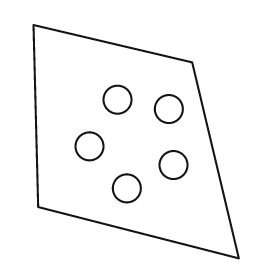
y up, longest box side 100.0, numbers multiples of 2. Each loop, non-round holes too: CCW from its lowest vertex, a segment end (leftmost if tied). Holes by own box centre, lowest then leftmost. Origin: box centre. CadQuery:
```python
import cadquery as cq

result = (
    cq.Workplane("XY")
    .moveTo(44.0, -50.0)
    .lineTo(24.0, 34.0)
    .lineTo(-44.0, 50.0)
    .lineTo(-42.0, -28.0)
    .close()
    .moveTo(-4.0, -20.0)
    .circle(6.0)
    .moveTo(16.0, -10.0)
    .circle(6.0)
    .moveTo(-20.0, -2.0)
    .circle(6.0)
    .moveTo(14.0, 14.0)
    .circle(6.0)
    .moveTo(-8.0, 18.0)
    .circle(6.0)
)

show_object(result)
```